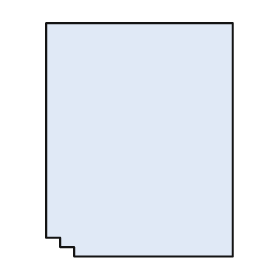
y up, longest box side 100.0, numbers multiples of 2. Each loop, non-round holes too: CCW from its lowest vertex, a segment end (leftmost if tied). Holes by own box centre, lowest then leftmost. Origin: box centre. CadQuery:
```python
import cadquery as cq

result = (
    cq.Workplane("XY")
    .moveTo(-28.0, -50.0)
    .lineTo(40.0, -50.0)
    .lineTo(40.0, 50.0)
    .lineTo(-40.0, 50.0)
    .lineTo(-40.0, -42.0)
    .lineTo(-34.0, -42.0)
    .lineTo(-34.0, -46.0)
    .lineTo(-28.0, -46.0)
    .close()
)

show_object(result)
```